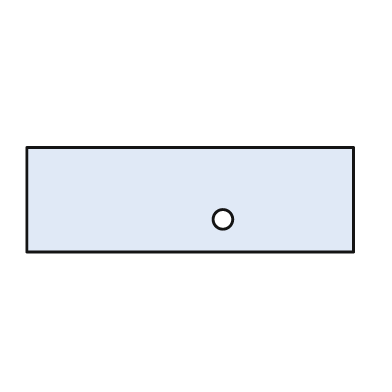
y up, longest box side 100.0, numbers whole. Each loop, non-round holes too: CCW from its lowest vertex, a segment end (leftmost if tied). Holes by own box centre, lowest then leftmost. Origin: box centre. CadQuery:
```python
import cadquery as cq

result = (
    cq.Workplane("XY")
    .moveTo(-50.0, -16.0)
    .lineTo(50.0, -16.0)
    .lineTo(50.0, 16.0)
    .lineTo(-50.0, 16.0)
    .close()
    .moveTo(10.0, -6.0)
    .circle(3.0)
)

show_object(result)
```